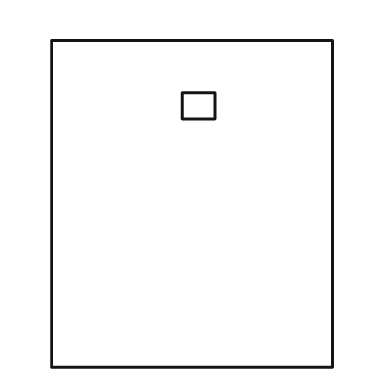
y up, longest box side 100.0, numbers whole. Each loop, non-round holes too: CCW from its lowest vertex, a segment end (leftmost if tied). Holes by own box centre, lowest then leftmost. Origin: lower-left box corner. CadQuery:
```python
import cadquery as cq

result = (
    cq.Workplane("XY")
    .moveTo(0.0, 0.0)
    .lineTo(86.0, 0.0)
    .lineTo(86.0, 100.0)
    .lineTo(0.0, 100.0)
    .close()
    .moveTo(40.0, 76.0)
    .lineTo(50.0, 76.0)
    .lineTo(50.0, 84.0)
    .lineTo(40.0, 84.0)
    .close()
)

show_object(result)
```